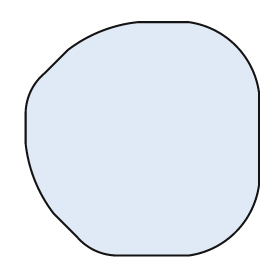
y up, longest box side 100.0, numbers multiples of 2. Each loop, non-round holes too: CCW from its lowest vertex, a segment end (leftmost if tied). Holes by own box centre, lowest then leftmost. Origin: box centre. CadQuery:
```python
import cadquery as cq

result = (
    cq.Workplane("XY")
    .moveTo(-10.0, -50.0)
    .lineTo(20.0, -50.0)
    .threePointArc((40.0, -40.0), (50.0, -20.0))
    .lineTo(50.0, 20.0)
    .threePointArc((40.0, 40.0), (20.0, 50.0))
    .lineTo(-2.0, 50.0)
    .threePointArc((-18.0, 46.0), (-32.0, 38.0))
    .lineTo(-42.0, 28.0)
    .threePointArc((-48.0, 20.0), (-50.0, 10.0))
    .lineTo(-50.0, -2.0)
    .threePointArc((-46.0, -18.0), (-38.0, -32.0))
    .lineTo(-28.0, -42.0)
    .threePointArc((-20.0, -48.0), (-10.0, -50.0))
    .close()
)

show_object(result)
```